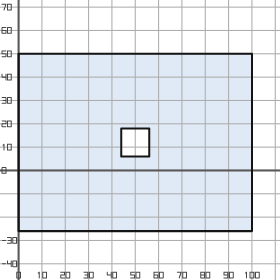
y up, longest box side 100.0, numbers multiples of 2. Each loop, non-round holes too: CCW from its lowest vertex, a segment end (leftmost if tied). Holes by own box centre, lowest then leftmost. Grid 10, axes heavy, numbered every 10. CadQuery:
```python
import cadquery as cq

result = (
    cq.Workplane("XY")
    .moveTo(0.0, -26.0)
    .lineTo(100.0, -26.0)
    .lineTo(100.0, 50.0)
    .lineTo(0.0, 50.0)
    .close()
    .moveTo(44.0, 6.0)
    .lineTo(56.0, 6.0)
    .lineTo(56.0, 18.0)
    .lineTo(44.0, 18.0)
    .close()
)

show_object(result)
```